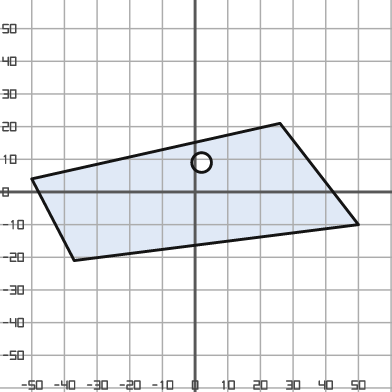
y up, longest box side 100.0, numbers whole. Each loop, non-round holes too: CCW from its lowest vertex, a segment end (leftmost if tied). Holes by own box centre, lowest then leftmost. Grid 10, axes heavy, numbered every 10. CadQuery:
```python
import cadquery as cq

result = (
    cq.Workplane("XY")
    .moveTo(-37.0, -21.0)
    .lineTo(50.0, -10.0)
    .lineTo(26.0, 21.0)
    .lineTo(-50.0, 4.0)
    .close()
    .moveTo(2.0, 9.0)
    .circle(3.0)
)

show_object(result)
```